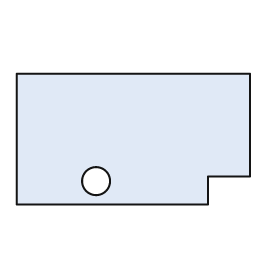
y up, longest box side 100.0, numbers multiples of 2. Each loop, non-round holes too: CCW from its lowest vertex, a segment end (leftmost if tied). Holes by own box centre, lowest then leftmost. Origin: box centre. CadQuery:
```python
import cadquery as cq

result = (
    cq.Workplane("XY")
    .moveTo(-50.0, -28.0)
    .lineTo(32.0, -28.0)
    .lineTo(32.0, -16.0)
    .lineTo(50.0, -16.0)
    .lineTo(50.0, 28.0)
    .lineTo(-50.0, 28.0)
    .close()
    .moveTo(-16.0, -18.0)
    .circle(6.0)
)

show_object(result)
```